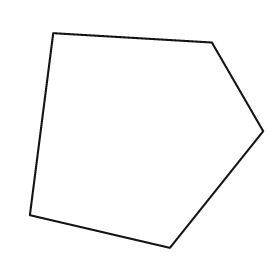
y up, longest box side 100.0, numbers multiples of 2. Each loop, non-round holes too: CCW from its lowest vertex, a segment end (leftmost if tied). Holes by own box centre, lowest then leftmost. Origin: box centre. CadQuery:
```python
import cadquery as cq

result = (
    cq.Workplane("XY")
    .moveTo(10.0, -46.0)
    .lineTo(50.0, 4.0)
    .lineTo(28.0, 42.0)
    .lineTo(-40.0, 46.0)
    .lineTo(-50.0, -32.0)
    .close()
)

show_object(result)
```